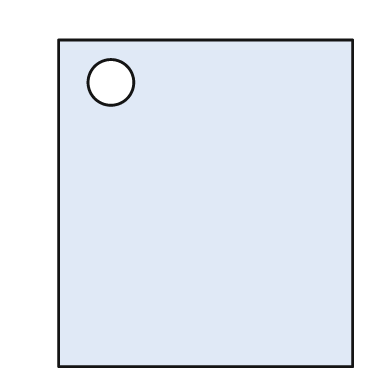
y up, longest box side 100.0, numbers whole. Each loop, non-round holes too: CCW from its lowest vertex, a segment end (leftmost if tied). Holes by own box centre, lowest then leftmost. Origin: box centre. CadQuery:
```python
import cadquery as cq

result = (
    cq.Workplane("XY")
    .moveTo(-45.0, -50.0)
    .lineTo(45.0, -50.0)
    .lineTo(45.0, 50.0)
    .lineTo(-45.0, 50.0)
    .close()
    .moveTo(-29.0, 37.0)
    .circle(7.0)
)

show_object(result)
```